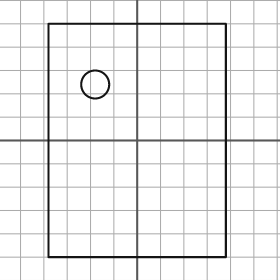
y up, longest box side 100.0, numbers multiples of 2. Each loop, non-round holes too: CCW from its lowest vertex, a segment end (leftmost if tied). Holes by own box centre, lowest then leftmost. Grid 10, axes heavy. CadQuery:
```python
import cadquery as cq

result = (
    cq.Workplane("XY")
    .moveTo(-38.0, -50.0)
    .lineTo(38.0, -50.0)
    .lineTo(38.0, 50.0)
    .lineTo(-38.0, 50.0)
    .close()
    .moveTo(-18.0, 24.0)
    .circle(6.0)
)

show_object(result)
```